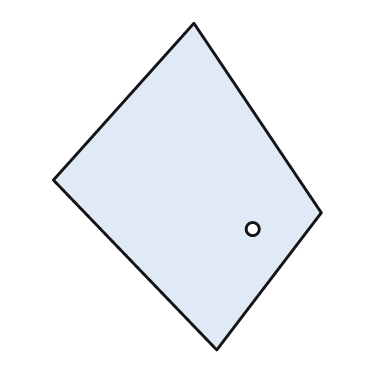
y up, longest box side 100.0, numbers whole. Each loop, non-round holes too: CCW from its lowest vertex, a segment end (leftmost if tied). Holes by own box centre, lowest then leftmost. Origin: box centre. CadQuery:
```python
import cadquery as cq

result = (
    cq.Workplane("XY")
    .moveTo(9.0, -50.0)
    .lineTo(41.0, -8.0)
    .lineTo(2.0, 50.0)
    .lineTo(-41.0, 2.0)
    .close()
    .moveTo(20.0, -13.0)
    .circle(2.0)
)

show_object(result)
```